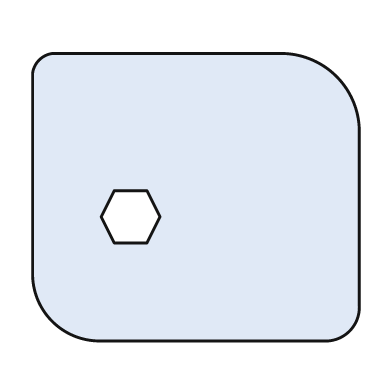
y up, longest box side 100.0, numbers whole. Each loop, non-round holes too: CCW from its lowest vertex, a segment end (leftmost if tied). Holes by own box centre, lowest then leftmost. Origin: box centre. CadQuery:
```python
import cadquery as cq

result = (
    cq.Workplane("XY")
    .moveTo(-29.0, -44.0)
    .lineTo(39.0, -44.0)
    .threePointArc((47.0, -41.0), (50.0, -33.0))
    .lineTo(50.0, 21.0)
    .threePointArc((43.0, 37.0), (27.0, 44.0))
    .lineTo(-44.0, 44.0)
    .threePointArc((-48.0, 42.0), (-50.0, 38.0))
    .lineTo(-50.0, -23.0)
    .threePointArc((-44.0, -38.0), (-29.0, -44.0))
    .close()
    .moveTo(-25.0, -14.0)
    .lineTo(-15.0, -14.0)
    .lineTo(-11.0, -6.0)
    .lineTo(-15.0, 2.0)
    .lineTo(-25.0, 2.0)
    .lineTo(-29.0, -6.0)
    .close()
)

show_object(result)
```